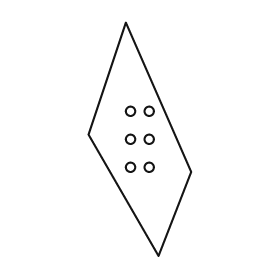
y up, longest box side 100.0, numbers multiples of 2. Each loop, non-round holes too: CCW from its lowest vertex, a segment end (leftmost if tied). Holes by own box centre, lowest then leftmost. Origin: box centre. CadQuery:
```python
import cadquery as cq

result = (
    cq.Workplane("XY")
    .moveTo(8.0, -50.0)
    .lineTo(22.0, -14.0)
    .lineTo(-6.0, 50.0)
    .lineTo(-22.0, 2.0)
    .close()
    .moveTo(-4.0, -12.0)
    .circle(2.0)
    .moveTo(4.0, -12.0)
    .circle(2.0)
    .moveTo(-4.0, 0.0)
    .circle(2.0)
    .moveTo(4.0, 0.0)
    .circle(2.0)
    .moveTo(-4.0, 12.0)
    .circle(2.0)
    .moveTo(4.0, 12.0)
    .circle(2.0)
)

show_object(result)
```